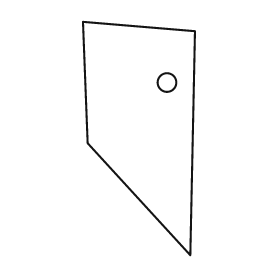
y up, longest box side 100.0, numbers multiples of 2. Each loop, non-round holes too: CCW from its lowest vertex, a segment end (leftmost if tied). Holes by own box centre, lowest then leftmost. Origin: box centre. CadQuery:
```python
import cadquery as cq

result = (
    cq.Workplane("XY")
    .moveTo(22.0, -50.0)
    .lineTo(24.0, 46.0)
    .lineTo(-24.0, 50.0)
    .lineTo(-22.0, -2.0)
    .close()
    .moveTo(12.0, 24.0)
    .circle(4.0)
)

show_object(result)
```